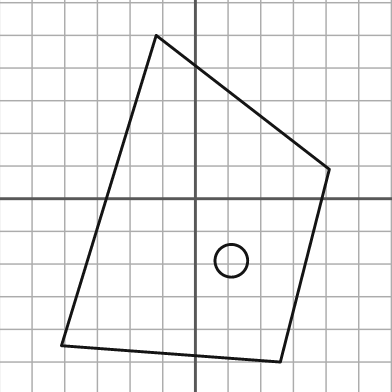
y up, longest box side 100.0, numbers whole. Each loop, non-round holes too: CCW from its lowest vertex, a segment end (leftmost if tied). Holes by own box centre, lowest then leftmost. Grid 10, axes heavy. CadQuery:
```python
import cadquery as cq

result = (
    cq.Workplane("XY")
    .moveTo(26.0, -50.0)
    .lineTo(41.0, 9.0)
    .lineTo(-12.0, 50.0)
    .lineTo(-41.0, -45.0)
    .close()
    .moveTo(11.0, -19.0)
    .circle(5.0)
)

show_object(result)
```